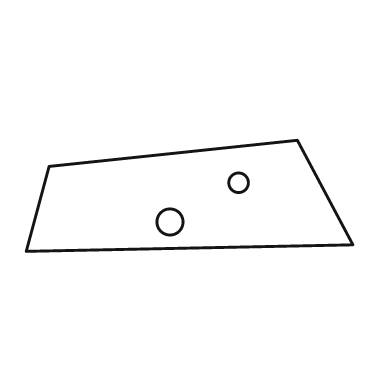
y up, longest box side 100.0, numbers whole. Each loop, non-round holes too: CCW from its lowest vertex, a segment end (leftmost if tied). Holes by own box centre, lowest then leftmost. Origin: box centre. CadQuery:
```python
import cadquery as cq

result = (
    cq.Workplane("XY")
    .moveTo(-50.0, -17.0)
    .lineTo(50.0, -15.0)
    .lineTo(33.0, 17.0)
    .lineTo(-43.0, 9.0)
    .close()
    .moveTo(-6.0, -8.0)
    .circle(4.0)
    .moveTo(15.0, 4.0)
    .circle(3.0)
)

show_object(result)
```